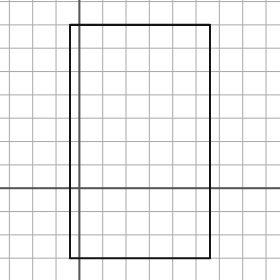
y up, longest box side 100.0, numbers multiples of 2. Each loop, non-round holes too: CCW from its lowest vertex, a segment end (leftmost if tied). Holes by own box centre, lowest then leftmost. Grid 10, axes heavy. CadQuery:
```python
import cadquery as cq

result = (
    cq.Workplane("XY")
    .moveTo(-4.0, -30.0)
    .lineTo(56.0, -30.0)
    .lineTo(56.0, 70.0)
    .lineTo(-4.0, 70.0)
    .close()
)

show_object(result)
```